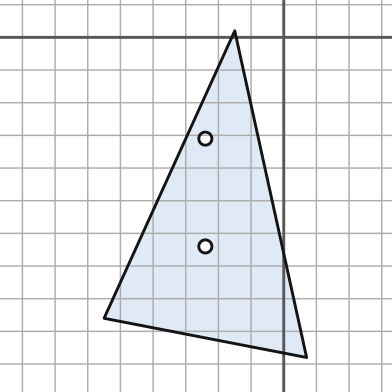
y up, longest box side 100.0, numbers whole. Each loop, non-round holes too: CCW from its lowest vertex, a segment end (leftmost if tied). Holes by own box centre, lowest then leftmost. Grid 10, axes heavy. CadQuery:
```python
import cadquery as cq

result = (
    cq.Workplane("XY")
    .moveTo(7.0, -98.0)
    .lineTo(-15.0, 2.0)
    .lineTo(-55.0, -86.0)
    .close()
    .moveTo(-24.0, -64.0)
    .circle(2.0)
    .moveTo(-24.0, -31.0)
    .circle(2.0)
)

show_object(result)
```